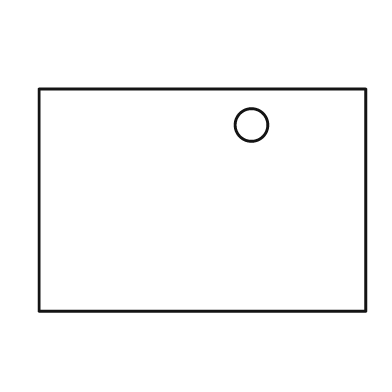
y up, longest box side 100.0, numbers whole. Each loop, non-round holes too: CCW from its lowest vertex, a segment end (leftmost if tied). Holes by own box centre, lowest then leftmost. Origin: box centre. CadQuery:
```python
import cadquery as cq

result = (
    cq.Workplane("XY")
    .moveTo(-50.0, -34.0)
    .lineTo(50.0, -34.0)
    .lineTo(50.0, 34.0)
    .lineTo(-50.0, 34.0)
    .close()
    .moveTo(15.0, 23.0)
    .circle(5.0)
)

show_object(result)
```